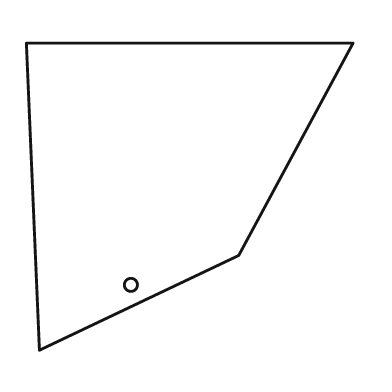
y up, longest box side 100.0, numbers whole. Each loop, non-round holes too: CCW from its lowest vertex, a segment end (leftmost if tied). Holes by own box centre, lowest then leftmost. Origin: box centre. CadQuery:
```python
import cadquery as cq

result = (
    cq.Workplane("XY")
    .moveTo(-46.0, -47.0)
    .lineTo(15.0, -18.0)
    .lineTo(50.0, 47.0)
    .lineTo(-50.0, 47.0)
    .close()
    .moveTo(-18.0, -27.0)
    .circle(2.0)
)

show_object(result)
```